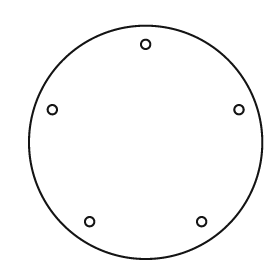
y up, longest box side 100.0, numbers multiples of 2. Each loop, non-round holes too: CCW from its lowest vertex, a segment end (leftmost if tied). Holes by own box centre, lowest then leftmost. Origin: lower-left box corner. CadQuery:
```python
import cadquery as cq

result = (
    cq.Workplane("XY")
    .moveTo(50.0, 50.0)
    .circle(50.0)
    .moveTo(26.0, 16.0)
    .circle(2.0)
    .moveTo(74.0, 16.0)
    .circle(2.0)
    .moveTo(10.0, 64.0)
    .circle(2.0)
    .moveTo(90.0, 64.0)
    .circle(2.0)
    .moveTo(50.0, 92.0)
    .circle(2.0)
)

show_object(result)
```